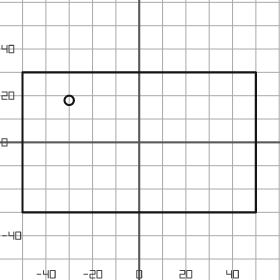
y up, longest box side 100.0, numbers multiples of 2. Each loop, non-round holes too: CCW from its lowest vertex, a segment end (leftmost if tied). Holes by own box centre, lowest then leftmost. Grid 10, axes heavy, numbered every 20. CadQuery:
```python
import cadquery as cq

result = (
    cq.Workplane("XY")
    .moveTo(-50.0, -30.0)
    .lineTo(50.0, -30.0)
    .lineTo(50.0, 30.0)
    .lineTo(-50.0, 30.0)
    .close()
    .moveTo(-30.0, 18.0)
    .circle(2.0)
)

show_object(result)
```